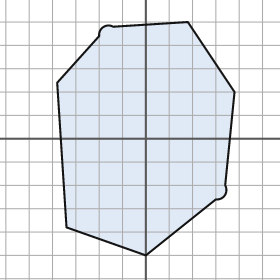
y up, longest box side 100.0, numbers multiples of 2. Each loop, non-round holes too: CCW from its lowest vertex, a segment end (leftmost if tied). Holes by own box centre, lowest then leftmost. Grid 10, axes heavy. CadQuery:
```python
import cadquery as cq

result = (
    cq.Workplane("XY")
    .moveTo(0.0, -50.0)
    .lineTo(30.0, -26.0)
    .threePointArc((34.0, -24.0), (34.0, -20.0))
    .lineTo(38.0, 20.0)
    .lineTo(18.0, 50.0)
    .lineTo(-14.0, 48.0)
    .threePointArc((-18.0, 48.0), (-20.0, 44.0))
    .lineTo(-38.0, 24.0)
    .lineTo(-34.0, -38.0)
    .close()
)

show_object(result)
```